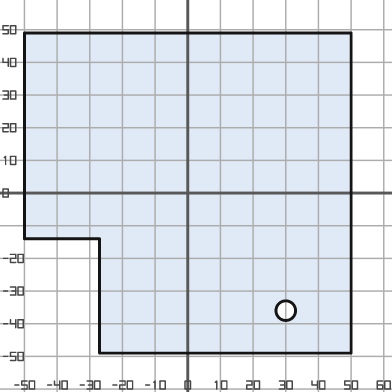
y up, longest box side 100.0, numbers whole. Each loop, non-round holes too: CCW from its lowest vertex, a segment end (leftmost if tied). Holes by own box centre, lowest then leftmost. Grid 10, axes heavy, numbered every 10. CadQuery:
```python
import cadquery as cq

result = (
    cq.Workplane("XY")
    .moveTo(-27.0, -49.0)
    .lineTo(50.0, -49.0)
    .lineTo(50.0, 49.0)
    .lineTo(-50.0, 49.0)
    .lineTo(-50.0, -14.0)
    .lineTo(-27.0, -14.0)
    .close()
    .moveTo(30.0, -36.0)
    .circle(3.0)
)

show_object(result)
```